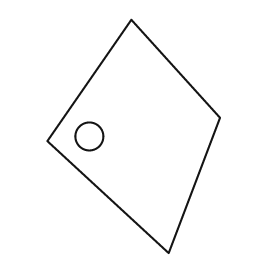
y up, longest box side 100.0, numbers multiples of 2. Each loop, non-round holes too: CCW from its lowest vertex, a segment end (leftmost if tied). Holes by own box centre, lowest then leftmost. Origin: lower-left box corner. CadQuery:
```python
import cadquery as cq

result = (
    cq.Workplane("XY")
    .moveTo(52.0, 0.0)
    .lineTo(74.0, 58.0)
    .lineTo(36.0, 100.0)
    .lineTo(0.0, 48.0)
    .close()
    .moveTo(18.0, 50.0)
    .circle(6.0)
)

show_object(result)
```